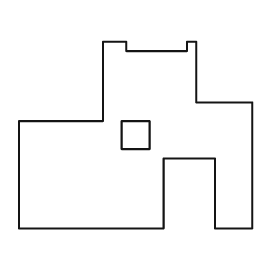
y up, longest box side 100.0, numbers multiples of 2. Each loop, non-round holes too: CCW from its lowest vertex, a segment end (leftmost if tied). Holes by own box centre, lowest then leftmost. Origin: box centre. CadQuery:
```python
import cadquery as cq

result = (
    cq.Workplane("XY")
    .moveTo(-50.0, -40.0)
    .lineTo(12.0, -40.0)
    .lineTo(12.0, -10.0)
    .lineTo(34.0, -10.0)
    .lineTo(34.0, -40.0)
    .lineTo(50.0, -40.0)
    .lineTo(50.0, 14.0)
    .lineTo(26.0, 14.0)
    .lineTo(26.0, 40.0)
    .lineTo(22.0, 40.0)
    .lineTo(22.0, 36.0)
    .lineTo(-4.0, 36.0)
    .lineTo(-4.0, 40.0)
    .lineTo(-14.0, 40.0)
    .lineTo(-14.0, 6.0)
    .lineTo(-50.0, 6.0)
    .close()
    .moveTo(-6.0, -6.0)
    .lineTo(6.0, -6.0)
    .lineTo(6.0, 6.0)
    .lineTo(-6.0, 6.0)
    .close()
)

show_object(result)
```